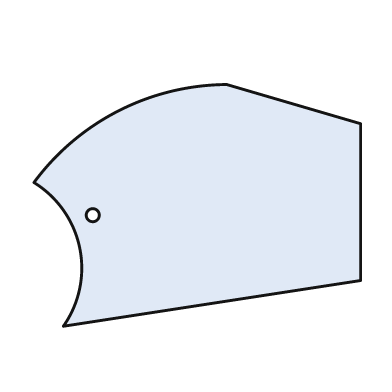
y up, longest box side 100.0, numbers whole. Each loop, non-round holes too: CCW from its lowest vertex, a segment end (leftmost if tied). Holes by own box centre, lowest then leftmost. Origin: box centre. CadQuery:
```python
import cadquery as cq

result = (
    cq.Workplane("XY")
    .moveTo(-41.0, -37.0)
    .lineTo(50.0, -23.0)
    .lineTo(50.0, 25.0)
    .lineTo(9.0, 37.0)
    .threePointArc((-24.0, 29.0), (-50.0, 7.0))
    .threePointArc((-36.0, -13.0), (-41.0, -37.0))
    .close()
    .moveTo(-32.0, -3.0)
    .circle(2.0)
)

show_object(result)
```